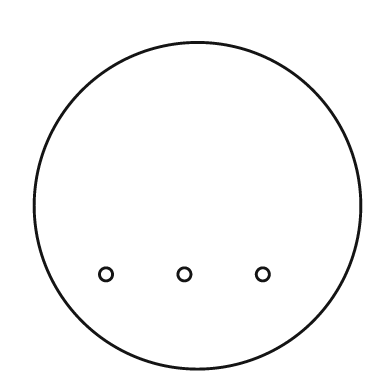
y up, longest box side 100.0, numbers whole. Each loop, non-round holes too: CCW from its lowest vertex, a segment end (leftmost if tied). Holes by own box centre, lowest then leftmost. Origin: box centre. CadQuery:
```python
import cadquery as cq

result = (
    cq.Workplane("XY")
    .moveTo(0.0, 0.0)
    .circle(50.0)
    .moveTo(-28.0, -21.0)
    .circle(2.0)
    .moveTo(-4.0, -21.0)
    .circle(2.0)
    .moveTo(20.0, -21.0)
    .circle(2.0)
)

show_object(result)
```